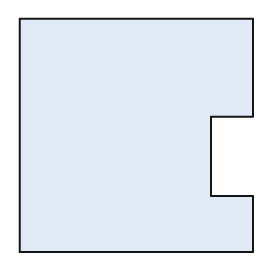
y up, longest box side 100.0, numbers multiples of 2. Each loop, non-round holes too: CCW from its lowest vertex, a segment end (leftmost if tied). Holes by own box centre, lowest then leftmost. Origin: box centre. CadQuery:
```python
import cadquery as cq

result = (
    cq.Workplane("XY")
    .moveTo(-50.0, -50.0)
    .lineTo(50.0, -50.0)
    .lineTo(50.0, -26.0)
    .lineTo(32.0, -26.0)
    .lineTo(32.0, 8.0)
    .lineTo(50.0, 8.0)
    .lineTo(50.0, 50.0)
    .lineTo(-50.0, 50.0)
    .close()
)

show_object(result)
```